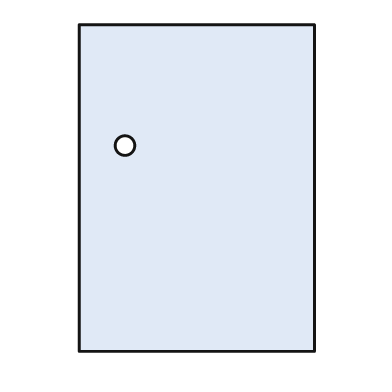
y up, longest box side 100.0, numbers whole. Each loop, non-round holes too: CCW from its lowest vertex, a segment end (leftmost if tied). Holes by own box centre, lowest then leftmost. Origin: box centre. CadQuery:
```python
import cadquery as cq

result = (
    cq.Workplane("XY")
    .moveTo(-36.0, -50.0)
    .lineTo(36.0, -50.0)
    .lineTo(36.0, 50.0)
    .lineTo(-36.0, 50.0)
    .close()
    .moveTo(-22.0, 13.0)
    .circle(3.0)
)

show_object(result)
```